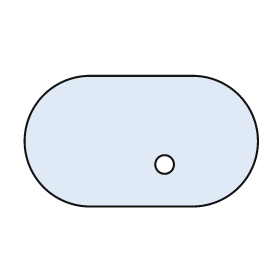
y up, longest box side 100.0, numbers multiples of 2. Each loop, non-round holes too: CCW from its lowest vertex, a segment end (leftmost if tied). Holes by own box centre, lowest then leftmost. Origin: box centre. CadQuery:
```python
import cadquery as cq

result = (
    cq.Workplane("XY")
    .moveTo(-22.0, -28.0)
    .lineTo(22.0, -28.0)
    .threePointArc((50.0, 0.0), (22.0, 28.0))
    .lineTo(-22.0, 28.0)
    .threePointArc((-50.0, 0.0), (-22.0, -28.0))
    .close()
    .moveTo(10.0, -10.0)
    .circle(4.0)
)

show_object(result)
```